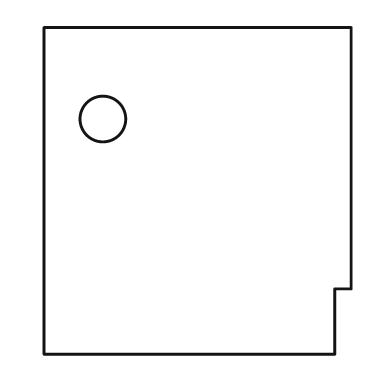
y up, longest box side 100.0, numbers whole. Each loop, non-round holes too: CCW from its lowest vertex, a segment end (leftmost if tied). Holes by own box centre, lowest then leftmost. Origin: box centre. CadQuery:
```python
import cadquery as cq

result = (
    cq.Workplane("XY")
    .moveTo(-47.0, -50.0)
    .lineTo(42.0, -50.0)
    .lineTo(42.0, -30.0)
    .lineTo(47.0, -30.0)
    .lineTo(47.0, 50.0)
    .lineTo(-47.0, 50.0)
    .close()
    .moveTo(-29.0, 22.0)
    .circle(7.0)
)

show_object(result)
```